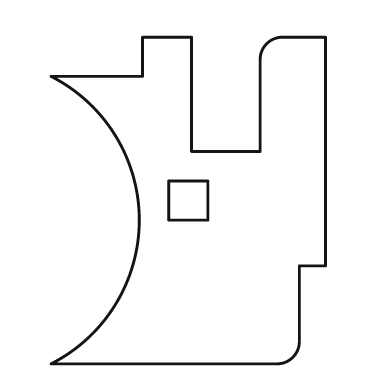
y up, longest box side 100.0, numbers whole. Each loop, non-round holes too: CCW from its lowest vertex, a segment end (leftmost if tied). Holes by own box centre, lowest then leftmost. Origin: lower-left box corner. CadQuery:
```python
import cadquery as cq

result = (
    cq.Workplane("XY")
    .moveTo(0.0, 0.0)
    .lineTo(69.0, 0.0)
    .threePointArc((74.0, 2.0), (76.0, 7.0))
    .lineTo(76.0, 30.0)
    .lineTo(84.0, 30.0)
    .lineTo(84.0, 100.0)
    .lineTo(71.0, 100.0)
    .threePointArc((66.0, 98.0), (64.0, 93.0))
    .lineTo(64.0, 65.0)
    .lineTo(43.0, 65.0)
    .lineTo(43.0, 100.0)
    .lineTo(28.0, 100.0)
    .lineTo(28.0, 88.0)
    .lineTo(0.0, 88.0)
    .threePointArc((27.0, 44.0), (0.0, 0.0))
    .close()
    .moveTo(36.0, 44.0)
    .lineTo(48.0, 44.0)
    .lineTo(48.0, 56.0)
    .lineTo(36.0, 56.0)
    .close()
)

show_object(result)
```